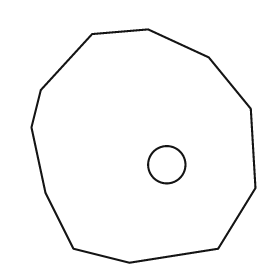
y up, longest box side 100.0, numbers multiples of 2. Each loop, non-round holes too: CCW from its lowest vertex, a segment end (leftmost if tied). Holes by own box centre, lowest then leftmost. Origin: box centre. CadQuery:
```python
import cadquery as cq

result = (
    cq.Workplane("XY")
    .moveTo(-6.0, -50.0)
    .lineTo(32.0, -44.0)
    .lineTo(48.0, -18.0)
    .lineTo(46.0, 16.0)
    .lineTo(28.0, 38.0)
    .lineTo(2.0, 50.0)
    .lineTo(-22.0, 48.0)
    .lineTo(-44.0, 24.0)
    .lineTo(-48.0, 8.0)
    .lineTo(-42.0, -20.0)
    .lineTo(-30.0, -44.0)
    .close()
    .moveTo(10.0, -8.0)
    .circle(8.0)
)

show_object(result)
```